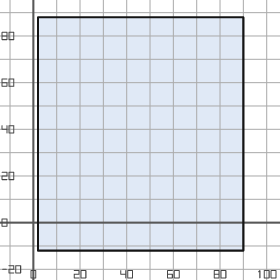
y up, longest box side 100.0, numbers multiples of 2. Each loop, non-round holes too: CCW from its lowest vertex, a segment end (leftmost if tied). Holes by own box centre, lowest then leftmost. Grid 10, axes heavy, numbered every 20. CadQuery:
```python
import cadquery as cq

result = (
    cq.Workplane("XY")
    .moveTo(2.0, -12.0)
    .lineTo(90.0, -12.0)
    .lineTo(90.0, 88.0)
    .lineTo(2.0, 88.0)
    .close()
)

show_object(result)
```